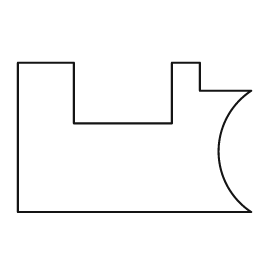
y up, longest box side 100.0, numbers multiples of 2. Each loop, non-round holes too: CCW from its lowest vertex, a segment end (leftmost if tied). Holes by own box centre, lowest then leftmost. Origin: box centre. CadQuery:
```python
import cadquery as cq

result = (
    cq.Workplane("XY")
    .moveTo(-50.0, -32.0)
    .lineTo(50.0, -32.0)
    .threePointArc((36.0, -6.0), (50.0, 20.0))
    .lineTo(28.0, 20.0)
    .lineTo(28.0, 32.0)
    .lineTo(16.0, 32.0)
    .lineTo(16.0, 6.0)
    .lineTo(-26.0, 6.0)
    .lineTo(-26.0, 32.0)
    .lineTo(-50.0, 32.0)
    .close()
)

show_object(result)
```